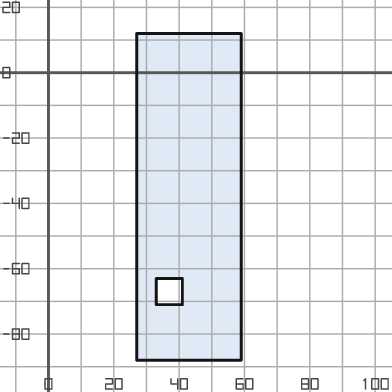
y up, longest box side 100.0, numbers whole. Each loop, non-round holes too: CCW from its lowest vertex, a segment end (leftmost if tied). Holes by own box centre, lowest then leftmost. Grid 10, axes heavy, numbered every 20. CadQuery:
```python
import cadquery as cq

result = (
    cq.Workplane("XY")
    .moveTo(27.0, -88.0)
    .lineTo(59.0, -88.0)
    .lineTo(59.0, 12.0)
    .lineTo(27.0, 12.0)
    .close()
    .moveTo(33.0, -71.0)
    .lineTo(41.0, -71.0)
    .lineTo(41.0, -63.0)
    .lineTo(33.0, -63.0)
    .close()
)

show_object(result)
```